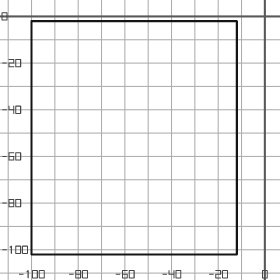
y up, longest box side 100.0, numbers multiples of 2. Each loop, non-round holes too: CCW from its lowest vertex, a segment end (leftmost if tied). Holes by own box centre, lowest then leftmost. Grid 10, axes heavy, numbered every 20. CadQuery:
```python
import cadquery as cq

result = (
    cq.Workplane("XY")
    .moveTo(-100.0, -102.0)
    .lineTo(-12.0, -102.0)
    .lineTo(-12.0, -2.0)
    .lineTo(-100.0, -2.0)
    .close()
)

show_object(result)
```